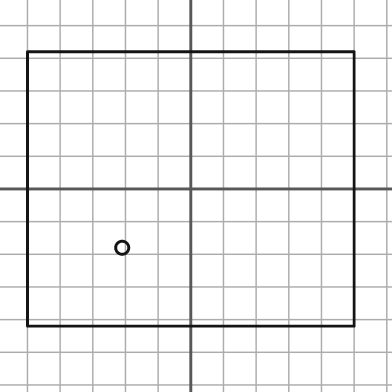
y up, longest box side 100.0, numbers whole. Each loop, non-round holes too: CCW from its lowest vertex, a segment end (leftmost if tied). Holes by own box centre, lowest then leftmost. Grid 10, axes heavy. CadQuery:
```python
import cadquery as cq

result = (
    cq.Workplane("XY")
    .moveTo(-50.0, -42.0)
    .lineTo(50.0, -42.0)
    .lineTo(50.0, 42.0)
    .lineTo(-50.0, 42.0)
    .close()
    .moveTo(-21.0, -18.0)
    .circle(2.0)
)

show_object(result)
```